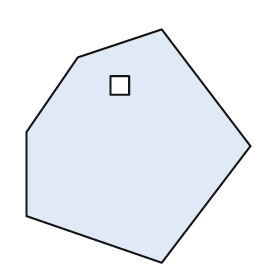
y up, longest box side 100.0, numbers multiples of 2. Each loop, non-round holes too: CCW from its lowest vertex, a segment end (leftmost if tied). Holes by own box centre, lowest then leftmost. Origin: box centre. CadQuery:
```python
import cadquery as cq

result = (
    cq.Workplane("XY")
    .moveTo(10.0, -50.0)
    .lineTo(48.0, 0.0)
    .lineTo(10.0, 50.0)
    .lineTo(-26.0, 38.0)
    .lineTo(-48.0, 6.0)
    .lineTo(-48.0, -30.0)
    .close()
    .moveTo(-12.0, 22.0)
    .lineTo(-4.0, 22.0)
    .lineTo(-4.0, 30.0)
    .lineTo(-12.0, 30.0)
    .close()
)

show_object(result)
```